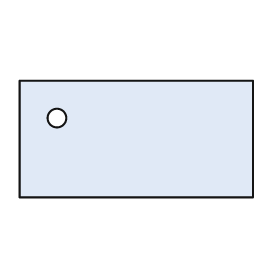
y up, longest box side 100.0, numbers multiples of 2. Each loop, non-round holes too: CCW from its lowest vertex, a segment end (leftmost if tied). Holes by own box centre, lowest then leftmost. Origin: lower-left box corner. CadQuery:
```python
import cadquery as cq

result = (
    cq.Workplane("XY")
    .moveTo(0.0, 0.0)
    .lineTo(100.0, 0.0)
    .lineTo(100.0, 50.0)
    .lineTo(0.0, 50.0)
    .close()
    .moveTo(16.0, 34.0)
    .circle(4.0)
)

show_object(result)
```